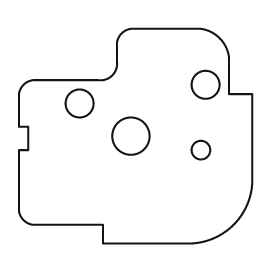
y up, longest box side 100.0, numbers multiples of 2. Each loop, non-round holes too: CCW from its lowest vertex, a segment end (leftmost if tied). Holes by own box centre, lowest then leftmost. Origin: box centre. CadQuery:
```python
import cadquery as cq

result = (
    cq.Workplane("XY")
    .moveTo(-14.0, -46.0)
    .lineTo(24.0, -46.0)
    .threePointArc((42.0, -38.0), (50.0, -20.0))
    .lineTo(50.0, 18.0)
    .lineTo(40.0, 18.0)
    .lineTo(40.0, 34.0)
    .threePointArc((36.0, 42.0), (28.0, 46.0))
    .lineTo(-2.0, 46.0)
    .threePointArc((-6.0, 44.0), (-8.0, 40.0))
    .lineTo(-8.0, 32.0)
    .threePointArc((-10.0, 26.0), (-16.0, 24.0))
    .lineTo(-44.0, 24.0)
    .threePointArc((-48.0, 22.0), (-50.0, 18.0))
    .lineTo(-50.0, 4.0)
    .lineTo(-46.0, 4.0)
    .lineTo(-46.0, -6.0)
    .lineTo(-50.0, -6.0)
    .lineTo(-50.0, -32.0)
    .threePointArc((-48.0, -36.0), (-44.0, -38.0))
    .lineTo(-14.0, -38.0)
    .close()
    .moveTo(28.0, -6.0)
    .circle(4.0)
    .moveTo(-2.0, 0.0)
    .circle(8.0)
    .moveTo(-24.0, 14.0)
    .circle(6.0)
    .moveTo(30.0, 22.0)
    .circle(6.0)
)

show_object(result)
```